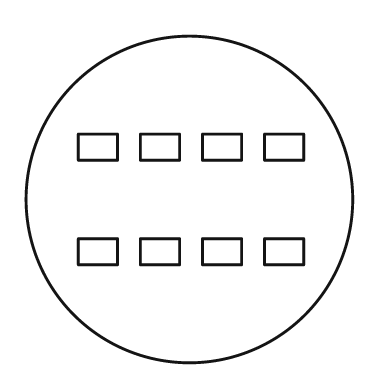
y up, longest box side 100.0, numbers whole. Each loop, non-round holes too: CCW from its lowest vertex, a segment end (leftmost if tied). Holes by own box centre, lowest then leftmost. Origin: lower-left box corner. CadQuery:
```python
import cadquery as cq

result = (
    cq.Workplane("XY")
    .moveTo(50.0, 50.0)
    .circle(50.0)
    .moveTo(16.0, 30.0)
    .lineTo(28.0, 30.0)
    .lineTo(28.0, 38.0)
    .lineTo(16.0, 38.0)
    .close()
    .moveTo(35.0, 30.0)
    .lineTo(47.0, 30.0)
    .lineTo(47.0, 38.0)
    .lineTo(35.0, 38.0)
    .close()
    .moveTo(54.0, 30.0)
    .lineTo(66.0, 30.0)
    .lineTo(66.0, 38.0)
    .lineTo(54.0, 38.0)
    .close()
    .moveTo(73.0, 30.0)
    .lineTo(85.0, 30.0)
    .lineTo(85.0, 38.0)
    .lineTo(73.0, 38.0)
    .close()
    .moveTo(16.0, 62.0)
    .lineTo(28.0, 62.0)
    .lineTo(28.0, 70.0)
    .lineTo(16.0, 70.0)
    .close()
    .moveTo(35.0, 62.0)
    .lineTo(47.0, 62.0)
    .lineTo(47.0, 70.0)
    .lineTo(35.0, 70.0)
    .close()
    .moveTo(54.0, 62.0)
    .lineTo(66.0, 62.0)
    .lineTo(66.0, 70.0)
    .lineTo(54.0, 70.0)
    .close()
    .moveTo(73.0, 62.0)
    .lineTo(85.0, 62.0)
    .lineTo(85.0, 70.0)
    .lineTo(73.0, 70.0)
    .close()
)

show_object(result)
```